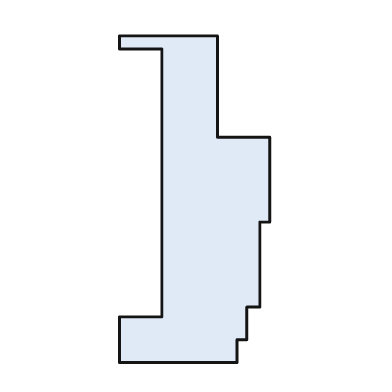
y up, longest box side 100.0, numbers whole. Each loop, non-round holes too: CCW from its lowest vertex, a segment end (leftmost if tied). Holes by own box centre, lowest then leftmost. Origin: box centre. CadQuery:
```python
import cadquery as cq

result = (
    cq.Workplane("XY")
    .moveTo(-23.0, -50.0)
    .lineTo(13.0, -50.0)
    .lineTo(13.0, -43.0)
    .lineTo(16.0, -43.0)
    .lineTo(16.0, -33.0)
    .lineTo(20.0, -33.0)
    .lineTo(20.0, -7.0)
    .lineTo(23.0, -7.0)
    .lineTo(23.0, 19.0)
    .lineTo(7.0, 19.0)
    .lineTo(7.0, 50.0)
    .lineTo(-23.0, 50.0)
    .lineTo(-23.0, 46.0)
    .lineTo(-10.0, 46.0)
    .lineTo(-10.0, -36.0)
    .lineTo(-23.0, -36.0)
    .close()
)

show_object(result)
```